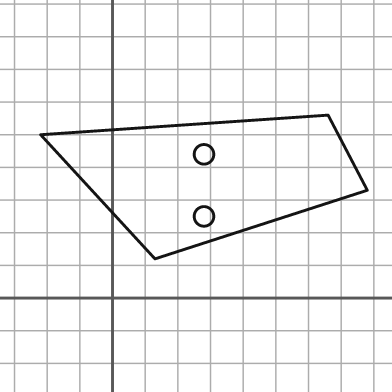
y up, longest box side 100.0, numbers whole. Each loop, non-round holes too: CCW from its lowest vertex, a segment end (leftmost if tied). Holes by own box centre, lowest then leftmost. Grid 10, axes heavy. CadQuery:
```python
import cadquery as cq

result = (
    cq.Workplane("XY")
    .moveTo(13.0, 12.0)
    .lineTo(78.0, 33.0)
    .lineTo(66.0, 56.0)
    .lineTo(-22.0, 50.0)
    .close()
    .moveTo(28.0, 25.0)
    .circle(3.0)
    .moveTo(28.0, 44.0)
    .circle(3.0)
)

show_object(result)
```